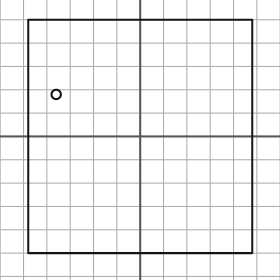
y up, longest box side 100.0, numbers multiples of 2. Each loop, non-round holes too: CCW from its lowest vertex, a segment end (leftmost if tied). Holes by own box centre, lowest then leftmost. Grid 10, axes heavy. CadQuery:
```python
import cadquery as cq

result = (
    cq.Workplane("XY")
    .moveTo(-48.0, -50.0)
    .lineTo(48.0, -50.0)
    .lineTo(48.0, 50.0)
    .lineTo(-48.0, 50.0)
    .close()
    .moveTo(-36.0, 18.0)
    .circle(2.0)
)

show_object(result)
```